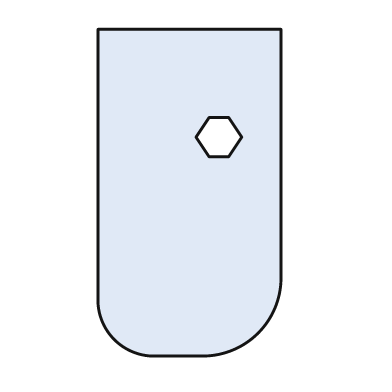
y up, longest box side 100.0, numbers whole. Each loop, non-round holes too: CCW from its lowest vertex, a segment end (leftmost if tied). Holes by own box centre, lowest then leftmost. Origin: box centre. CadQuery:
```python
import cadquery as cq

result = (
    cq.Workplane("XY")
    .moveTo(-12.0, -50.0)
    .lineTo(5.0, -50.0)
    .threePointArc((21.0, -43.0), (28.0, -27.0))
    .lineTo(28.0, 50.0)
    .lineTo(-28.0, 50.0)
    .lineTo(-28.0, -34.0)
    .threePointArc((-23.0, -45.0), (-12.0, -50.0))
    .close()
    .moveTo(6.0, 11.0)
    .lineTo(12.0, 11.0)
    .lineTo(16.0, 17.0)
    .lineTo(12.0, 23.0)
    .lineTo(6.0, 23.0)
    .lineTo(2.0, 17.0)
    .close()
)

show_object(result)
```